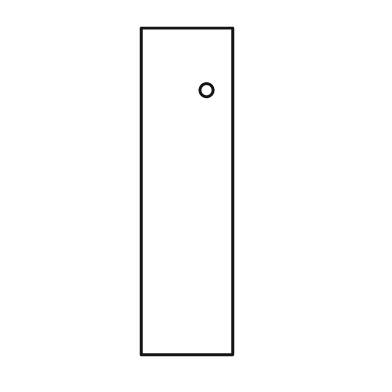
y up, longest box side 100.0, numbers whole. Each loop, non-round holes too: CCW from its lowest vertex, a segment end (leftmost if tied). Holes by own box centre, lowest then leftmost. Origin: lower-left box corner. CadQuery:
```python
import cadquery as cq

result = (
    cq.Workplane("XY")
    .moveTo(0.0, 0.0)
    .lineTo(28.0, 0.0)
    .lineTo(28.0, 100.0)
    .lineTo(0.0, 100.0)
    .close()
    .moveTo(20.0, 81.0)
    .circle(2.0)
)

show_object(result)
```